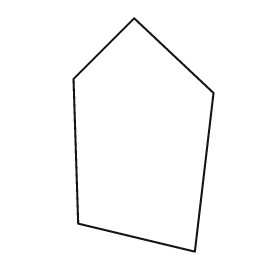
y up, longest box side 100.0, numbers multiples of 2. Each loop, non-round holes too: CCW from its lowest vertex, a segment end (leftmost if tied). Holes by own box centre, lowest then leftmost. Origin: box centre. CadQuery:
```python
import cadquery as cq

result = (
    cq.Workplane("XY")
    .moveTo(22.0, -50.0)
    .lineTo(30.0, 18.0)
    .lineTo(-4.0, 50.0)
    .lineTo(-30.0, 24.0)
    .lineTo(-28.0, -38.0)
    .close()
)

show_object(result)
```